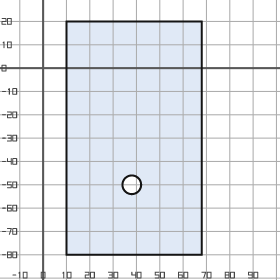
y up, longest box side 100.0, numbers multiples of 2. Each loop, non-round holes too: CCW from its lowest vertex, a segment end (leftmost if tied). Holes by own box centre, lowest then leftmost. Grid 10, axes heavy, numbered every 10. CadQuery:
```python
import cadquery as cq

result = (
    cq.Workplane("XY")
    .moveTo(10.0, -80.0)
    .lineTo(68.0, -80.0)
    .lineTo(68.0, 20.0)
    .lineTo(10.0, 20.0)
    .close()
    .moveTo(38.0, -50.0)
    .circle(4.0)
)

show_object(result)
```